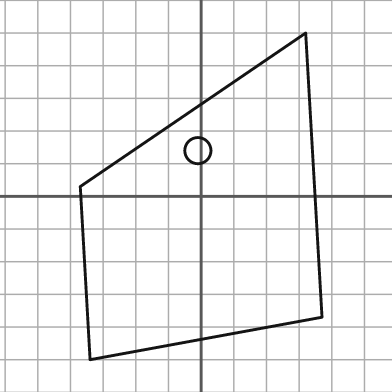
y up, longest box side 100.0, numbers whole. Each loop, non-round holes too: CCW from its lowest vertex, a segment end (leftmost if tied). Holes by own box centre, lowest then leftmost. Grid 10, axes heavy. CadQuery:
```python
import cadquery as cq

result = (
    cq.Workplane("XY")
    .moveTo(-34.0, -50.0)
    .lineTo(37.0, -37.0)
    .lineTo(32.0, 50.0)
    .lineTo(-37.0, 3.0)
    .close()
    .moveTo(-1.0, 14.0)
    .circle(4.0)
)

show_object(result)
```